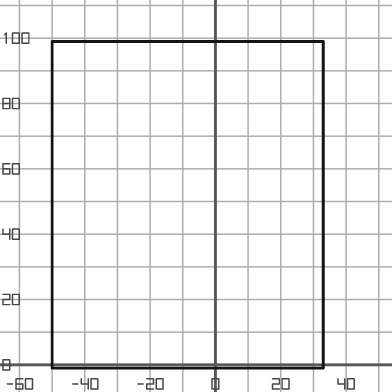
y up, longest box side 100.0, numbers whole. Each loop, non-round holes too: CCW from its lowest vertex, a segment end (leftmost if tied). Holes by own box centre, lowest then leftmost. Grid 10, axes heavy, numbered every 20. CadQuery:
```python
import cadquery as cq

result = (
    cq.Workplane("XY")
    .moveTo(-50.0, -1.0)
    .lineTo(33.0, -1.0)
    .lineTo(33.0, 99.0)
    .lineTo(-50.0, 99.0)
    .close()
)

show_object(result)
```